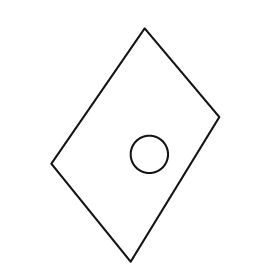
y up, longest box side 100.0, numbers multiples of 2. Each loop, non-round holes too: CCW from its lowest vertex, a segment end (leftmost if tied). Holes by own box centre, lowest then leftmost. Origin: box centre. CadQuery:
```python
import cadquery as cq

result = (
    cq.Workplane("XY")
    .moveTo(-2.0, -50.0)
    .lineTo(36.0, 12.0)
    .lineTo(4.0, 50.0)
    .lineTo(-36.0, -8.0)
    .close()
    .moveTo(6.0, -4.0)
    .circle(8.0)
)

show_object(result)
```